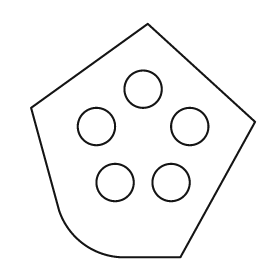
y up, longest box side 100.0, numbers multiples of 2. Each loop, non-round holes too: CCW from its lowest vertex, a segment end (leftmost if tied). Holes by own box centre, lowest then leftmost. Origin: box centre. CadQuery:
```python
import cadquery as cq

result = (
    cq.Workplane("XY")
    .moveTo(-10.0, -50.0)
    .lineTo(16.0, -50.0)
    .lineTo(48.0, 8.0)
    .lineTo(2.0, 50.0)
    .lineTo(-48.0, 14.0)
    .lineTo(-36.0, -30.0)
    .threePointArc((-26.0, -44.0), (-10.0, -50.0))
    .close()
    .moveTo(-12.0, -18.0)
    .circle(8.0)
    .moveTo(12.0, -18.0)
    .circle(8.0)
    .moveTo(-20.0, 6.0)
    .circle(8.0)
    .moveTo(20.0, 6.0)
    .circle(8.0)
    .moveTo(0.0, 22.0)
    .circle(8.0)
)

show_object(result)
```